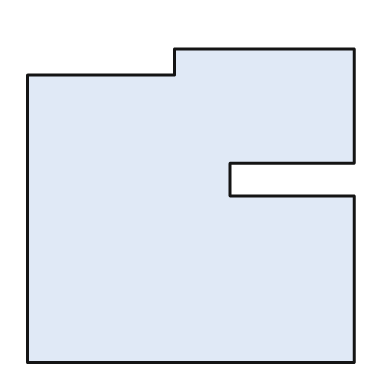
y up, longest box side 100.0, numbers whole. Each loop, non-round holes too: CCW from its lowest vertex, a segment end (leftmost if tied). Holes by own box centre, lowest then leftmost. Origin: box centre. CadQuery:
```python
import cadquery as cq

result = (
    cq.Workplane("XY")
    .moveTo(-50.0, -48.0)
    .lineTo(50.0, -48.0)
    .lineTo(50.0, 3.0)
    .lineTo(12.0, 3.0)
    .lineTo(12.0, 13.0)
    .lineTo(50.0, 13.0)
    .lineTo(50.0, 48.0)
    .lineTo(-5.0, 48.0)
    .lineTo(-5.0, 40.0)
    .lineTo(-50.0, 40.0)
    .close()
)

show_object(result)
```